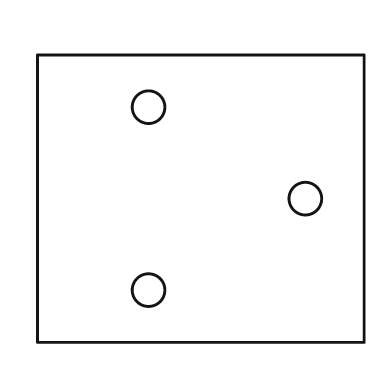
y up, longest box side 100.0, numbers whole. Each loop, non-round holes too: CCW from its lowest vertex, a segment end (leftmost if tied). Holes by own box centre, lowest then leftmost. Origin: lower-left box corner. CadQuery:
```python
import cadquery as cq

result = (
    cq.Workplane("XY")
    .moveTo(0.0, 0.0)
    .lineTo(100.0, 0.0)
    .lineTo(100.0, 88.0)
    .lineTo(0.0, 88.0)
    .close()
    .moveTo(34.0, 16.0)
    .circle(5.0)
    .moveTo(82.0, 44.0)
    .circle(5.0)
    .moveTo(34.0, 72.0)
    .circle(5.0)
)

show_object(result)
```